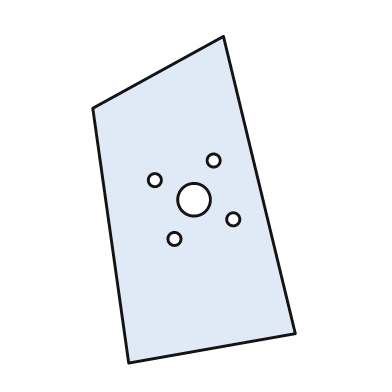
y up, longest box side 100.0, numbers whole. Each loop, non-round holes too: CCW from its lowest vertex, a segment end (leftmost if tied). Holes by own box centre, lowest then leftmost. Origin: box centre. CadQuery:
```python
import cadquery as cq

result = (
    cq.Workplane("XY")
    .moveTo(-20.0, -50.0)
    .lineTo(31.0, -41.0)
    .lineTo(9.0, 50.0)
    .lineTo(-31.0, 28.0)
    .close()
    .moveTo(-6.0, -12.0)
    .circle(2.0)
    .moveTo(12.0, -6.0)
    .circle(2.0)
    .moveTo(0.0, 0.0)
    .circle(5.0)
    .moveTo(-12.0, 6.0)
    .circle(2.0)
    .moveTo(6.0, 12.0)
    .circle(2.0)
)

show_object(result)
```